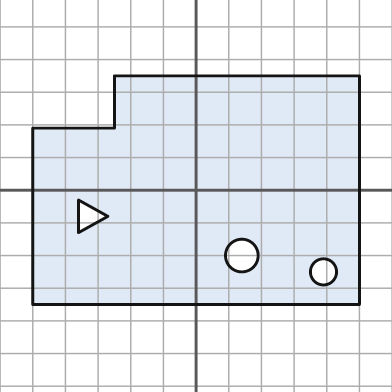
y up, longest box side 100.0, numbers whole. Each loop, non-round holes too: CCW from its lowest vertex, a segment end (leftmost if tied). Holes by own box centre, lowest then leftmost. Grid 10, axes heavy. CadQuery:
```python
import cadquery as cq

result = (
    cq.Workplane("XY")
    .moveTo(-50.0, -35.0)
    .lineTo(50.0, -35.0)
    .lineTo(50.0, 35.0)
    .lineTo(-25.0, 35.0)
    .lineTo(-25.0, 19.0)
    .lineTo(-50.0, 19.0)
    .close()
    .moveTo(39.0, -25.0)
    .circle(4.0)
    .moveTo(14.0, -20.0)
    .circle(5.0)
    .moveTo(-36.0, -13.0)
    .lineTo(-27.0, -8.0)
    .lineTo(-36.0, -3.0)
    .close()
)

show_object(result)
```